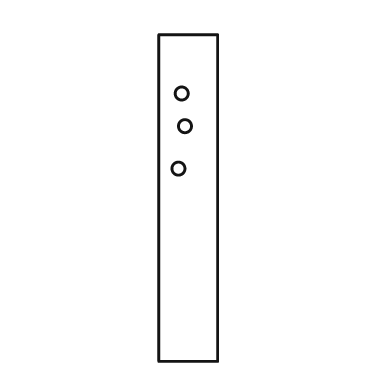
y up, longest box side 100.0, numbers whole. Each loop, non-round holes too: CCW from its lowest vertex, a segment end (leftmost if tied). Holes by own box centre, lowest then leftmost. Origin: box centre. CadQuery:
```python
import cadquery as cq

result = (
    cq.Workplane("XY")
    .moveTo(-9.0, -50.0)
    .lineTo(9.0, -50.0)
    .lineTo(9.0, 50.0)
    .lineTo(-9.0, 50.0)
    .close()
    .moveTo(-3.0, 9.0)
    .circle(2.0)
    .moveTo(-1.0, 22.0)
    .circle(2.0)
    .moveTo(-2.0, 32.0)
    .circle(2.0)
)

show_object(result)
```